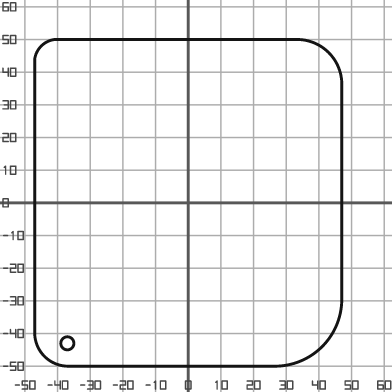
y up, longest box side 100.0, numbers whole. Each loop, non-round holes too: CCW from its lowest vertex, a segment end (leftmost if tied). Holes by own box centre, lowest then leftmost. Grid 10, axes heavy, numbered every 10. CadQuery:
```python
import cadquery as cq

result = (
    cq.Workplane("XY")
    .moveTo(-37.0, -50.0)
    .lineTo(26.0, -50.0)
    .threePointArc((41.0, -44.0), (47.0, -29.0))
    .lineTo(47.0, 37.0)
    .threePointArc((43.0, 46.0), (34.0, 50.0))
    .lineTo(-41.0, 50.0)
    .threePointArc((-45.0, 48.0), (-47.0, 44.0))
    .lineTo(-47.0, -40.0)
    .threePointArc((-44.0, -47.0), (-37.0, -50.0))
    .close()
    .moveTo(-37.0, -43.0)
    .circle(2.0)
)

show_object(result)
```